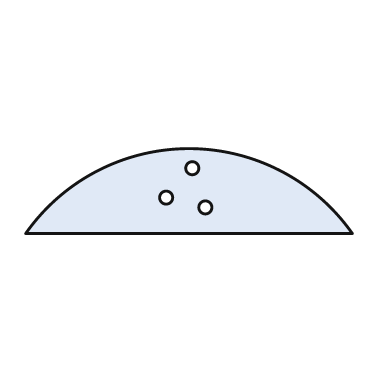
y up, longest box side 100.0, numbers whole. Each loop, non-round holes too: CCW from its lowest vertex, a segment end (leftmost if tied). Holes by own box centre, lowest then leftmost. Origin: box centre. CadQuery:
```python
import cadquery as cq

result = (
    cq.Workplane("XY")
    .moveTo(-50.0, -13.0)
    .lineTo(50.0, -13.0)
    .threePointArc((0.0, 13.0), (-50.0, -13.0))
    .close()
    .moveTo(5.0, -5.0)
    .circle(2.0)
    .moveTo(-7.0, -2.0)
    .circle(2.0)
    .moveTo(1.0, 7.0)
    .circle(2.0)
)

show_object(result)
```